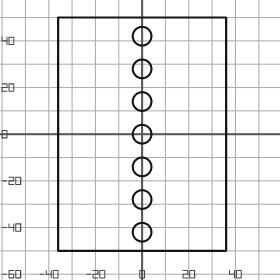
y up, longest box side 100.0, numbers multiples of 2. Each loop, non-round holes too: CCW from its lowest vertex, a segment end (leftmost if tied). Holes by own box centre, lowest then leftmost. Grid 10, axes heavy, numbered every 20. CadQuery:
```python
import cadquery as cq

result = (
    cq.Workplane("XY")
    .moveTo(-36.0, -50.0)
    .lineTo(36.0, -50.0)
    .lineTo(36.0, 50.0)
    .lineTo(-36.0, 50.0)
    .close()
    .moveTo(0.0, -42.0)
    .circle(4.0)
    .moveTo(0.0, -28.0)
    .circle(4.0)
    .moveTo(0.0, -14.0)
    .circle(4.0)
    .moveTo(0.0, 0.0)
    .circle(4.0)
    .moveTo(0.0, 14.0)
    .circle(4.0)
    .moveTo(0.0, 28.0)
    .circle(4.0)
    .moveTo(0.0, 42.0)
    .circle(4.0)
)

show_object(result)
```